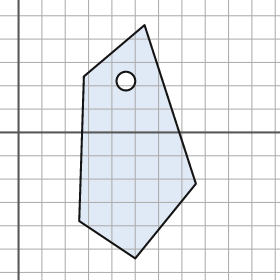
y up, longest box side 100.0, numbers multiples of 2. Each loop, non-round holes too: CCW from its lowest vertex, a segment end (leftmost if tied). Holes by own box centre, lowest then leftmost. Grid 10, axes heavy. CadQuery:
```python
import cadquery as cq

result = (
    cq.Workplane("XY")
    .moveTo(50.0, -54.0)
    .lineTo(76.0, -22.0)
    .lineTo(54.0, 46.0)
    .lineTo(28.0, 24.0)
    .lineTo(26.0, -38.0)
    .close()
    .moveTo(46.0, 22.0)
    .circle(4.0)
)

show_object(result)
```